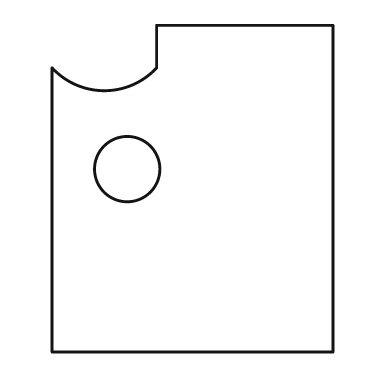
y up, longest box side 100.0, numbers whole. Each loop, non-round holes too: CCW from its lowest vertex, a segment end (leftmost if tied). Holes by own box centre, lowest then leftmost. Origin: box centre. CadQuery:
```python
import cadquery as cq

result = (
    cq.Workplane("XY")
    .moveTo(-43.0, -50.0)
    .lineTo(43.0, -50.0)
    .lineTo(43.0, 50.0)
    .lineTo(-11.0, 50.0)
    .lineTo(-11.0, 37.0)
    .threePointArc((-27.0, 30.0), (-43.0, 37.0))
    .close()
    .moveTo(-20.0, 6.0)
    .circle(10.0)
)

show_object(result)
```